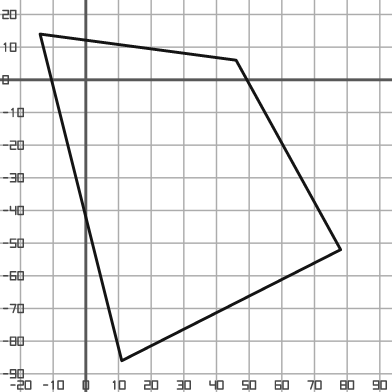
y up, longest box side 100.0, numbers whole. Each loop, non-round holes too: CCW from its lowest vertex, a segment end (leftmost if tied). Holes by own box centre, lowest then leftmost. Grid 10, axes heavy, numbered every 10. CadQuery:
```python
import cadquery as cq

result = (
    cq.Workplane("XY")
    .moveTo(11.0, -86.0)
    .lineTo(78.0, -52.0)
    .lineTo(46.0, 6.0)
    .lineTo(-14.0, 14.0)
    .close()
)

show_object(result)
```